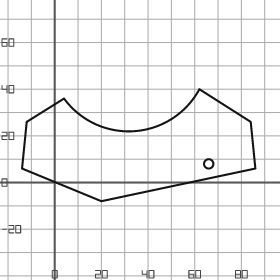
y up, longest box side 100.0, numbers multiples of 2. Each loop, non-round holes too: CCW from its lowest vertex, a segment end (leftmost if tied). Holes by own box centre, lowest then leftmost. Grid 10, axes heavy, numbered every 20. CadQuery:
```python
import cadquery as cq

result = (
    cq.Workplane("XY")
    .moveTo(20.0, -8.0)
    .lineTo(86.0, 6.0)
    .lineTo(84.0, 26.0)
    .lineTo(62.0, 40.0)
    .threePointArc((34.0, 22.0), (4.0, 36.0))
    .lineTo(-12.0, 26.0)
    .lineTo(-14.0, 6.0)
    .close()
    .moveTo(66.0, 8.0)
    .circle(2.0)
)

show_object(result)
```